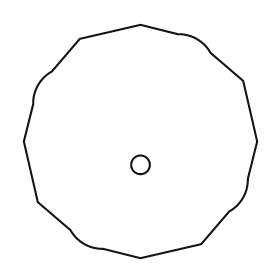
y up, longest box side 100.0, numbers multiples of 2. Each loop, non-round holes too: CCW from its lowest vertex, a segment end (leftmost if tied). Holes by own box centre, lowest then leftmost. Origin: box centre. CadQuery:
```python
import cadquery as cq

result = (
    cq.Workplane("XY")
    .moveTo(0.0, -50.0)
    .lineTo(26.0, -44.0)
    .lineTo(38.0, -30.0)
    .threePointArc((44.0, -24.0), (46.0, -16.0))
    .lineTo(50.0, 0.0)
    .lineTo(44.0, 26.0)
    .lineTo(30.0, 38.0)
    .threePointArc((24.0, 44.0), (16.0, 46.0))
    .lineTo(0.0, 50.0)
    .lineTo(-26.0, 44.0)
    .lineTo(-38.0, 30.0)
    .threePointArc((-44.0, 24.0), (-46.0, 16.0))
    .lineTo(-50.0, 0.0)
    .lineTo(-44.0, -26.0)
    .lineTo(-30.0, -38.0)
    .threePointArc((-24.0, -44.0), (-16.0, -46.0))
    .close()
    .moveTo(0.0, -10.0)
    .circle(4.0)
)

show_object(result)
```